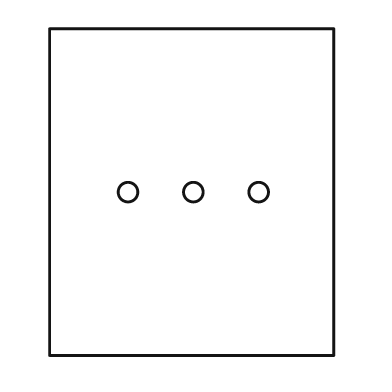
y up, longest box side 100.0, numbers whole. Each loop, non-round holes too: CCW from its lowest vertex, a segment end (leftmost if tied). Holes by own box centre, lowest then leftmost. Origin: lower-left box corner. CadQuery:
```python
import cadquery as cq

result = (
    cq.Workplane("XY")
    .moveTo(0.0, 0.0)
    .lineTo(87.0, 0.0)
    .lineTo(87.0, 100.0)
    .lineTo(0.0, 100.0)
    .close()
    .moveTo(24.0, 50.0)
    .circle(3.0)
    .moveTo(44.0, 50.0)
    .circle(3.0)
    .moveTo(64.0, 50.0)
    .circle(3.0)
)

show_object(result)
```